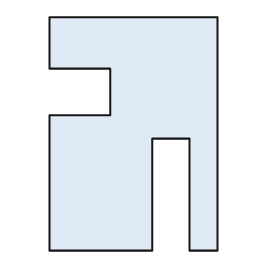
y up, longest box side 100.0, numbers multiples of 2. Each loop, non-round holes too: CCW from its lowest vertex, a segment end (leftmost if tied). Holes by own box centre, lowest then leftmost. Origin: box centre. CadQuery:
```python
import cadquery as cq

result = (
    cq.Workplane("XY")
    .moveTo(-36.0, -50.0)
    .lineTo(8.0, -50.0)
    .lineTo(8.0, -2.0)
    .lineTo(24.0, -2.0)
    .lineTo(24.0, -50.0)
    .lineTo(36.0, -50.0)
    .lineTo(36.0, 50.0)
    .lineTo(-36.0, 50.0)
    .lineTo(-36.0, 28.0)
    .lineTo(-10.0, 28.0)
    .lineTo(-10.0, 8.0)
    .lineTo(-36.0, 8.0)
    .close()
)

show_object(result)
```